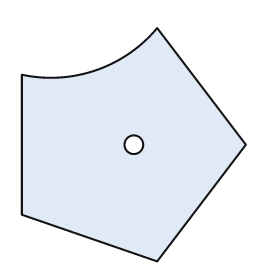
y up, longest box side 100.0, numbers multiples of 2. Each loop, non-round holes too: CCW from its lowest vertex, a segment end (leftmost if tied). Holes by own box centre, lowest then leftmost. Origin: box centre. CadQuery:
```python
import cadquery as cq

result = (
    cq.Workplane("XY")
    .moveTo(10.0, -50.0)
    .lineTo(48.0, 0.0)
    .lineTo(10.0, 50.0)
    .threePointArc((-16.0, 32.0), (-48.0, 30.0))
    .lineTo(-48.0, -30.0)
    .close()
    .moveTo(0.0, 0.0)
    .circle(4.0)
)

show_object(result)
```